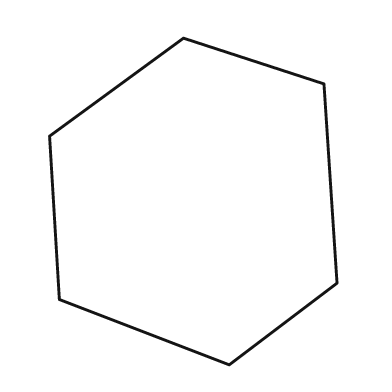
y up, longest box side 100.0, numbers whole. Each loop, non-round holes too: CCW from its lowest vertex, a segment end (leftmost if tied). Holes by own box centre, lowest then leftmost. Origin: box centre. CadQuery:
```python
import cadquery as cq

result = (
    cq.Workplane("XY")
    .moveTo(11.0, -50.0)
    .lineTo(44.0, -25.0)
    .lineTo(40.0, 36.0)
    .lineTo(-3.0, 50.0)
    .lineTo(-44.0, 20.0)
    .lineTo(-41.0, -30.0)
    .close()
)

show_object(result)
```